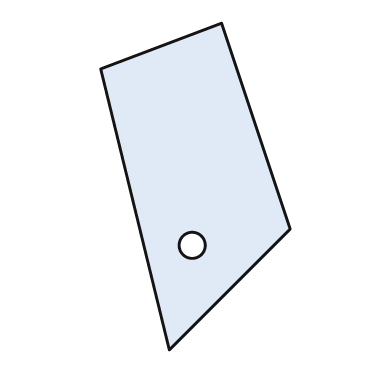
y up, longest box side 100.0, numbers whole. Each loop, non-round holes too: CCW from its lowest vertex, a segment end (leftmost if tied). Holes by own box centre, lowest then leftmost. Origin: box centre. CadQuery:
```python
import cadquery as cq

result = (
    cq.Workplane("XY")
    .moveTo(-8.0, -50.0)
    .lineTo(29.0, -13.0)
    .lineTo(8.0, 50.0)
    .lineTo(-29.0, 36.0)
    .close()
    .moveTo(-1.0, -18.0)
    .circle(4.0)
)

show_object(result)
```